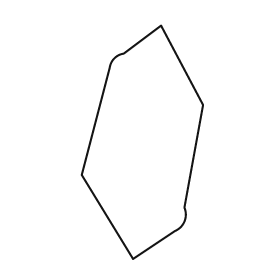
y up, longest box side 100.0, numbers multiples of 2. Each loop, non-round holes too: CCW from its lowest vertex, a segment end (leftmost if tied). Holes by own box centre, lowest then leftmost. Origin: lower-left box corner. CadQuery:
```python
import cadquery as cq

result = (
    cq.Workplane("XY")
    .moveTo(22.0, 0.0)
    .lineTo(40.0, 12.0)
    .threePointArc((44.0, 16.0), (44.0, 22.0))
    .lineTo(52.0, 66.0)
    .lineTo(34.0, 100.0)
    .lineTo(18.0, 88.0)
    .threePointArc((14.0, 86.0), (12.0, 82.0))
    .lineTo(0.0, 36.0)
    .close()
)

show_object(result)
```